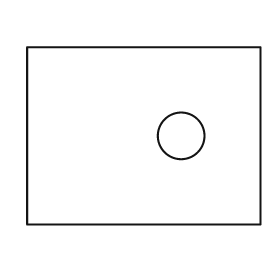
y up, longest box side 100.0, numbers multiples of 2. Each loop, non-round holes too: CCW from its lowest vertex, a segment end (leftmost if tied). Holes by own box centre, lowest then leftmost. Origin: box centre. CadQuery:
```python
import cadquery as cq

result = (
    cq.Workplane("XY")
    .moveTo(-50.0, -38.0)
    .lineTo(50.0, -38.0)
    .lineTo(50.0, 38.0)
    .lineTo(-50.0, 38.0)
    .close()
    .moveTo(16.0, 0.0)
    .circle(10.0)
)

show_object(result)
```